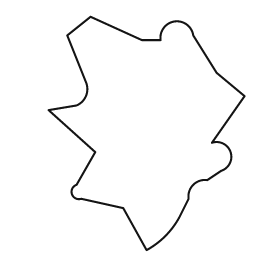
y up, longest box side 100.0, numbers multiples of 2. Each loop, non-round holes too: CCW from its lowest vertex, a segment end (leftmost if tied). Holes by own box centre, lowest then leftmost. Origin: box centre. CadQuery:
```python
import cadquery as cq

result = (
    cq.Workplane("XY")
    .moveTo(0.0, -50.0)
    .threePointArc((8.0, -44.0), (14.0, -36.0))
    .lineTo(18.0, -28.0)
    .threePointArc((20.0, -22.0), (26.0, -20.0))
    .lineTo(32.0, -16.0)
    .threePointArc((36.0, -8.0), (28.0, -4.0))
    .lineTo(42.0, 16.0)
    .lineTo(30.0, 26.0)
    .lineTo(20.0, 42.0)
    .threePointArc((12.0, 48.0), (6.0, 40.0))
    .lineTo(-2.0, 40.0)
    .lineTo(-24.0, 50.0)
    .lineTo(-34.0, 42.0)
    .lineTo(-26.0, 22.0)
    .threePointArc((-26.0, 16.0), (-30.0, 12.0))
    .lineTo(-42.0, 10.0)
    .lineTo(-22.0, -8.0)
    .lineTo(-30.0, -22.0)
    .threePointArc((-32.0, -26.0), (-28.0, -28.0))
    .lineTo(-10.0, -32.0)
    .close()
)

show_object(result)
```